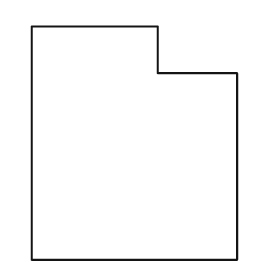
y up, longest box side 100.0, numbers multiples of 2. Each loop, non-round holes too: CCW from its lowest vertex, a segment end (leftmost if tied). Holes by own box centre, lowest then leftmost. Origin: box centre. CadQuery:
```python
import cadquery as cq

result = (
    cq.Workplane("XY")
    .moveTo(-44.0, -50.0)
    .lineTo(44.0, -50.0)
    .lineTo(44.0, 30.0)
    .lineTo(10.0, 30.0)
    .lineTo(10.0, 50.0)
    .lineTo(-44.0, 50.0)
    .close()
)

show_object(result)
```